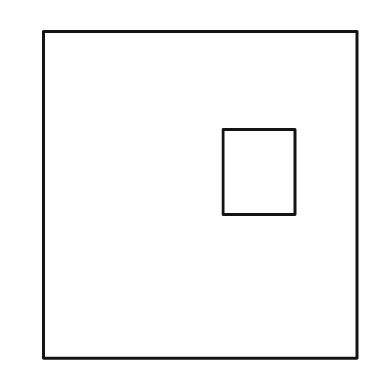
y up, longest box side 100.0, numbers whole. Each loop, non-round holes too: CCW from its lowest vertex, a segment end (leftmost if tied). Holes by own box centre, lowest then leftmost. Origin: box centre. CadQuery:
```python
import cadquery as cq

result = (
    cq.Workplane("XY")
    .moveTo(-48.0, -50.0)
    .lineTo(48.0, -50.0)
    .lineTo(48.0, 50.0)
    .lineTo(-48.0, 50.0)
    .close()
    .moveTo(7.0, -6.0)
    .lineTo(29.0, -6.0)
    .lineTo(29.0, 20.0)
    .lineTo(7.0, 20.0)
    .close()
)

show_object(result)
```